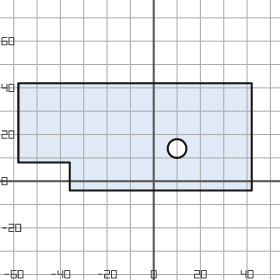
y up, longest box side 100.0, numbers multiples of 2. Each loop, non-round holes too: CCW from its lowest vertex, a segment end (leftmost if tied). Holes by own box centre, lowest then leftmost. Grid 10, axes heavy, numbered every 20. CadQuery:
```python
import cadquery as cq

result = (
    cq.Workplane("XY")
    .moveTo(-36.0, -4.0)
    .lineTo(42.0, -4.0)
    .lineTo(42.0, 42.0)
    .lineTo(-58.0, 42.0)
    .lineTo(-58.0, 8.0)
    .lineTo(-36.0, 8.0)
    .close()
    .moveTo(10.0, 14.0)
    .circle(4.0)
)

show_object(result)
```